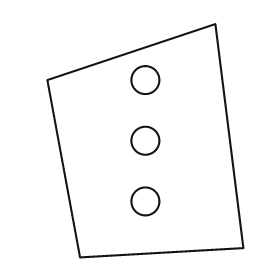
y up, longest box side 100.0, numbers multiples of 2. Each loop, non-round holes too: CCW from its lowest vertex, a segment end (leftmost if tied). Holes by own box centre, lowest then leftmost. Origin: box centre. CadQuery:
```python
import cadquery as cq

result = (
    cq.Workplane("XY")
    .moveTo(-28.0, -50.0)
    .lineTo(42.0, -46.0)
    .lineTo(30.0, 50.0)
    .lineTo(-42.0, 26.0)
    .close()
    .moveTo(0.0, -26.0)
    .circle(6.0)
    .moveTo(0.0, 0.0)
    .circle(6.0)
    .moveTo(0.0, 26.0)
    .circle(6.0)
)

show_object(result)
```